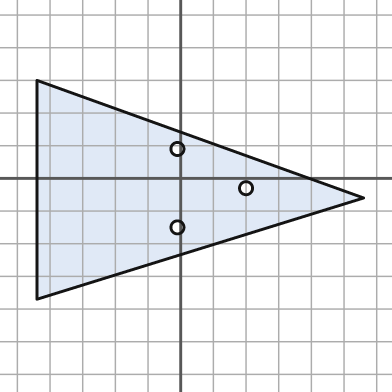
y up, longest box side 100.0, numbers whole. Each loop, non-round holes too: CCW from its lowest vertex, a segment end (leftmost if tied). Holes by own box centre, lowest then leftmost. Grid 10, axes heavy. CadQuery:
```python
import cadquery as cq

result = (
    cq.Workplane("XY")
    .moveTo(-44.0, -37.0)
    .lineTo(56.0, -6.0)
    .lineTo(-44.0, 30.0)
    .close()
    .moveTo(-1.0, -15.0)
    .circle(2.0)
    .moveTo(20.0, -3.0)
    .circle(2.0)
    .moveTo(-1.0, 9.0)
    .circle(2.0)
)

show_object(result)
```